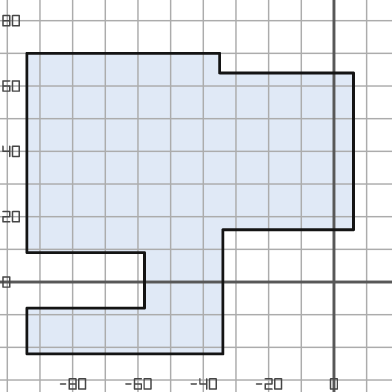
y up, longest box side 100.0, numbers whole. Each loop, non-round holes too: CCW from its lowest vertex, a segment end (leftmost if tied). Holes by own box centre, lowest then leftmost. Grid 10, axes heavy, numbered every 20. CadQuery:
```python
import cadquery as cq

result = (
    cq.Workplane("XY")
    .moveTo(-94.0, -22.0)
    .lineTo(-34.0, -22.0)
    .lineTo(-34.0, 16.0)
    .lineTo(6.0, 16.0)
    .lineTo(6.0, 64.0)
    .lineTo(-35.0, 64.0)
    .lineTo(-35.0, 70.0)
    .lineTo(-94.0, 70.0)
    .lineTo(-94.0, 9.0)
    .lineTo(-58.0, 9.0)
    .lineTo(-58.0, -8.0)
    .lineTo(-94.0, -8.0)
    .close()
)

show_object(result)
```